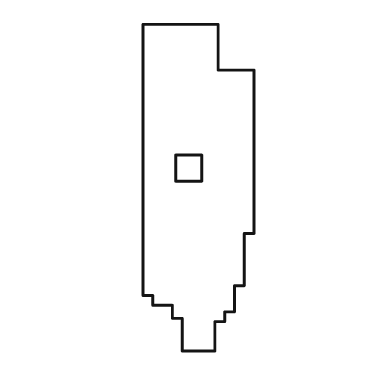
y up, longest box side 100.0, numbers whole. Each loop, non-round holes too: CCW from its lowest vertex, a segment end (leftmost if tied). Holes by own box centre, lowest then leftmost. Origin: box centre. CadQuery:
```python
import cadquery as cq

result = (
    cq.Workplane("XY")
    .moveTo(-5.0, -50.0)
    .lineTo(5.0, -50.0)
    .lineTo(5.0, -41.0)
    .lineTo(8.0, -41.0)
    .lineTo(8.0, -38.0)
    .lineTo(11.0, -38.0)
    .lineTo(11.0, -30.0)
    .lineTo(14.0, -30.0)
    .lineTo(14.0, -14.0)
    .lineTo(17.0, -14.0)
    .lineTo(17.0, 36.0)
    .lineTo(6.0, 36.0)
    .lineTo(6.0, 50.0)
    .lineTo(-17.0, 50.0)
    .lineTo(-17.0, -33.0)
    .lineTo(-14.0, -33.0)
    .lineTo(-14.0, -36.0)
    .lineTo(-8.0, -36.0)
    .lineTo(-8.0, -40.0)
    .lineTo(-5.0, -40.0)
    .close()
    .moveTo(-7.0, 2.0)
    .lineTo(1.0, 2.0)
    .lineTo(1.0, 10.0)
    .lineTo(-7.0, 10.0)
    .close()
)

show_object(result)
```